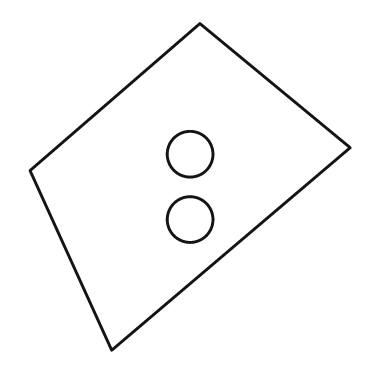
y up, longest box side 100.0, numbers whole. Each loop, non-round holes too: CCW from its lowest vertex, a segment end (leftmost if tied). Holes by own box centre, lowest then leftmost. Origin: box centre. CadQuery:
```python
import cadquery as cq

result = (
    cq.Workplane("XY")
    .moveTo(-24.0, -50.0)
    .lineTo(49.0, 12.0)
    .lineTo(3.0, 50.0)
    .lineTo(-49.0, 5.0)
    .close()
    .moveTo(0.0, -10.0)
    .circle(7.0)
    .moveTo(0.0, 10.0)
    .circle(7.0)
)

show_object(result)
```